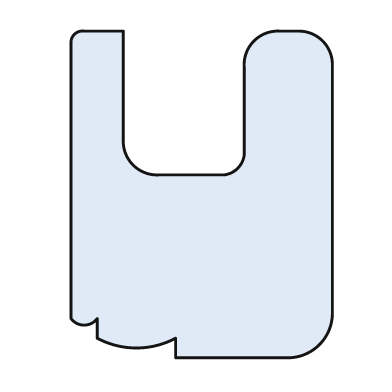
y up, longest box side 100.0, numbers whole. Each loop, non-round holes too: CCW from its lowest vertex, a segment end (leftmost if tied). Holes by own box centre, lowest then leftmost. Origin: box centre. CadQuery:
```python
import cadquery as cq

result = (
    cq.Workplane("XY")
    .moveTo(-8.0, -50.0)
    .lineTo(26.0, -50.0)
    .threePointArc((36.0, -46.0), (40.0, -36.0))
    .lineTo(40.0, 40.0)
    .threePointArc((37.0, 47.0), (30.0, 50.0))
    .lineTo(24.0, 50.0)
    .threePointArc((16.0, 47.0), (13.0, 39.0))
    .lineTo(13.0, 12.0)
    .threePointArc((11.0, 8.0), (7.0, 6.0))
    .lineTo(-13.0, 6.0)
    .threePointArc((-21.0, 9.0), (-24.0, 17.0))
    .lineTo(-24.0, 50.0)
    .lineTo(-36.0, 50.0)
    .threePointArc((-39.0, 49.0), (-40.0, 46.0))
    .lineTo(-40.0, -38.0)
    .threePointArc((-36.0, -40.0), (-32.0, -38.0))
    .lineTo(-32.0, -44.0)
    .threePointArc((-20.0, -47.0), (-8.0, -44.0))
    .close()
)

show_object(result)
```